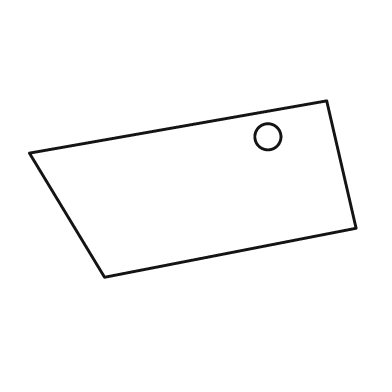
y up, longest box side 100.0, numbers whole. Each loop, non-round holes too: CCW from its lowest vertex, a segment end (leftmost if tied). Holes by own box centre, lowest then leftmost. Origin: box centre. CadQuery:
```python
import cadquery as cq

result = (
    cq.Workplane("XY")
    .moveTo(-27.0, -27.0)
    .lineTo(50.0, -12.0)
    .lineTo(41.0, 27.0)
    .lineTo(-50.0, 11.0)
    .close()
    .moveTo(23.0, 16.0)
    .circle(4.0)
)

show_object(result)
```